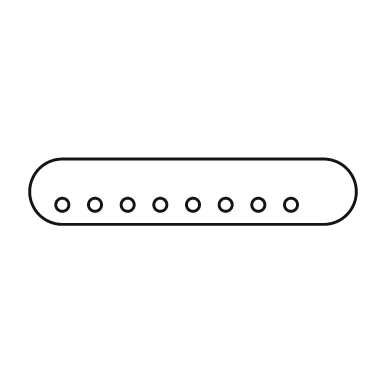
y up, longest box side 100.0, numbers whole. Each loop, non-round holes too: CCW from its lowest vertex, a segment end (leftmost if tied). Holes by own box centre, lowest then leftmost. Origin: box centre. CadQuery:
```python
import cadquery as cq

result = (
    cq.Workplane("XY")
    .moveTo(-40.0, -10.0)
    .lineTo(40.0, -10.0)
    .threePointArc((50.0, 0.0), (40.0, 10.0))
    .lineTo(-40.0, 10.0)
    .threePointArc((-50.0, 0.0), (-40.0, -10.0))
    .close()
    .moveTo(-40.0, -4.0)
    .circle(2.0)
    .moveTo(-30.0, -4.0)
    .circle(2.0)
    .moveTo(-20.0, -4.0)
    .circle(2.0)
    .moveTo(-10.0, -4.0)
    .circle(2.0)
    .moveTo(0.0, -4.0)
    .circle(2.0)
    .moveTo(10.0, -4.0)
    .circle(2.0)
    .moveTo(20.0, -4.0)
    .circle(2.0)
    .moveTo(30.0, -4.0)
    .circle(2.0)
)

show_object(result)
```